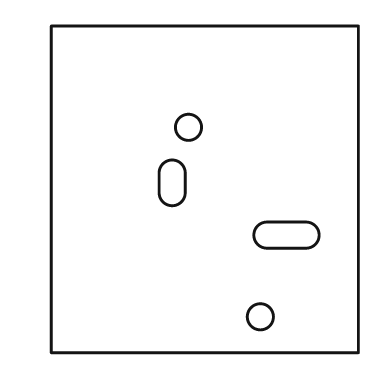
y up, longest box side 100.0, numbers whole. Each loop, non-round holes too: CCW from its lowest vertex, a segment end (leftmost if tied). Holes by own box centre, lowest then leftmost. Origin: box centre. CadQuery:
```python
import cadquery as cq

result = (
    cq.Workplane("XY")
    .moveTo(-47.0, -50.0)
    .lineTo(47.0, -50.0)
    .lineTo(47.0, 50.0)
    .lineTo(-47.0, 50.0)
    .close()
    .moveTo(17.0, -39.0)
    .circle(4.0)
    .moveTo(19.0, -18.0)
    .lineTo(31.0, -18.0)
    .threePointArc((35.0, -14.0), (31.0, -10.0))
    .lineTo(19.0, -10.0)
    .threePointArc((15.0, -14.0), (19.0, -18.0))
    .close()
    .moveTo(-14.0, -1.0)
    .threePointArc((-10.0, -5.0), (-6.0, -1.0))
    .lineTo(-6.0, 5.0)
    .threePointArc((-10.0, 9.0), (-14.0, 5.0))
    .close()
    .moveTo(-5.0, 19.0)
    .circle(4.0)
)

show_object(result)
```